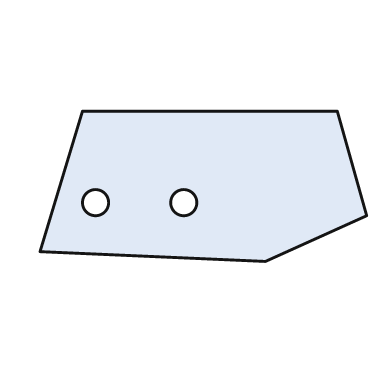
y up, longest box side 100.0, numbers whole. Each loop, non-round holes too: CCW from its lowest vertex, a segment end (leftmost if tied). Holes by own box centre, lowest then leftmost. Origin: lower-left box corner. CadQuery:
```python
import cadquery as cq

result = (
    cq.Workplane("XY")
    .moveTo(69.0, 0.0)
    .lineTo(100.0, 14.0)
    .lineTo(91.0, 46.0)
    .lineTo(13.0, 46.0)
    .lineTo(0.0, 3.0)
    .close()
    .moveTo(17.0, 18.0)
    .circle(4.0)
    .moveTo(44.0, 18.0)
    .circle(4.0)
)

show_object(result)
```